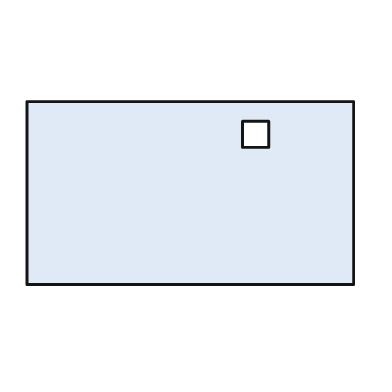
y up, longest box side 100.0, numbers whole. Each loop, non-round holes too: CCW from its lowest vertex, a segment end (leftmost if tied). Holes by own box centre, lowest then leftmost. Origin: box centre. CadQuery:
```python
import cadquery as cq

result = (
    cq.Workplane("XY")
    .moveTo(-50.0, -28.0)
    .lineTo(50.0, -28.0)
    .lineTo(50.0, 28.0)
    .lineTo(-50.0, 28.0)
    .close()
    .moveTo(16.0, 14.0)
    .lineTo(24.0, 14.0)
    .lineTo(24.0, 22.0)
    .lineTo(16.0, 22.0)
    .close()
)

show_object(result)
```